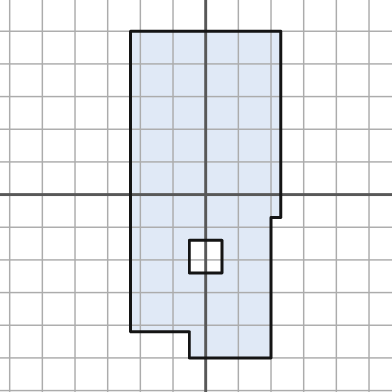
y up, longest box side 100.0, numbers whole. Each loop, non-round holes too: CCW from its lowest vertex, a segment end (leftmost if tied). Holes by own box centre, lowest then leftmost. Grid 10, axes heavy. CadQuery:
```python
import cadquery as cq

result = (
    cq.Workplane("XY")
    .moveTo(-5.0, -50.0)
    .lineTo(20.0, -50.0)
    .lineTo(20.0, -7.0)
    .lineTo(23.0, -7.0)
    .lineTo(23.0, 50.0)
    .lineTo(-23.0, 50.0)
    .lineTo(-23.0, -42.0)
    .lineTo(-5.0, -42.0)
    .close()
    .moveTo(-5.0, -24.0)
    .lineTo(5.0, -24.0)
    .lineTo(5.0, -14.0)
    .lineTo(-5.0, -14.0)
    .close()
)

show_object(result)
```